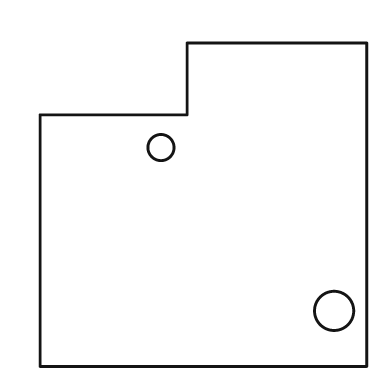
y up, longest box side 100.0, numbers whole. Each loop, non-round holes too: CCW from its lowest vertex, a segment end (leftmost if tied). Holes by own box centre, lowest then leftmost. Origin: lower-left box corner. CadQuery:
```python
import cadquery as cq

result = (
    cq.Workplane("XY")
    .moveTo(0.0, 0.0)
    .lineTo(100.0, 0.0)
    .lineTo(100.0, 99.0)
    .lineTo(45.0, 99.0)
    .lineTo(45.0, 77.0)
    .lineTo(0.0, 77.0)
    .close()
    .moveTo(90.0, 17.0)
    .circle(6.0)
    .moveTo(37.0, 67.0)
    .circle(4.0)
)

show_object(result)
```